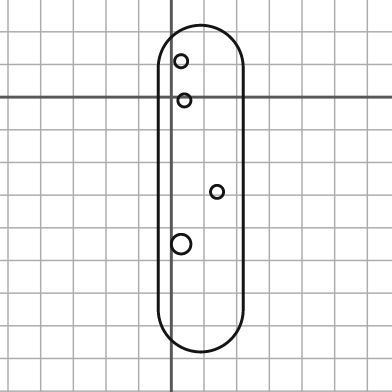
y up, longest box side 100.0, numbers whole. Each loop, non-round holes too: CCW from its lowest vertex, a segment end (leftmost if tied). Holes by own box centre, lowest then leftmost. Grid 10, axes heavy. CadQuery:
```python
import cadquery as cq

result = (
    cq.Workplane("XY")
    .moveTo(-4.0, -65.0)
    .threePointArc((9.0, -78.0), (22.0, -65.0))
    .lineTo(22.0, 9.0)
    .threePointArc((9.0, 22.0), (-4.0, 9.0))
    .close()
    .moveTo(3.0, -45.0)
    .circle(3.0)
    .moveTo(14.0, -29.0)
    .circle(2.0)
    .moveTo(4.0, -1.0)
    .circle(2.0)
    .moveTo(3.0, 11.0)
    .circle(2.0)
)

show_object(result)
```